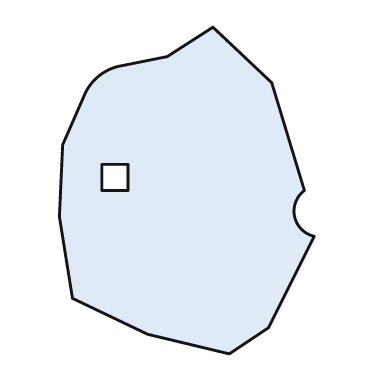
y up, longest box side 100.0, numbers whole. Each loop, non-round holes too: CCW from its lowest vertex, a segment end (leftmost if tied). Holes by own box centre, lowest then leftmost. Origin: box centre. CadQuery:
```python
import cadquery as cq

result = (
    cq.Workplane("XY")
    .moveTo(13.0, -50.0)
    .lineTo(25.0, -42.0)
    .lineTo(39.0, -14.0)
    .threePointArc((33.0, -8.0), (36.0, 0.0))
    .lineTo(26.0, 33.0)
    .lineTo(8.0, 50.0)
    .lineTo(-6.0, 41.0)
    .lineTo(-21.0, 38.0)
    .threePointArc((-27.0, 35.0), (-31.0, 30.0))
    .lineTo(-38.0, 14.0)
    .lineTo(-39.0, -8.0)
    .lineTo(-35.0, -33.0)
    .lineTo(-12.0, -44.0)
    .close()
    .moveTo(-26.0, 0.0)
    .lineTo(-18.0, 0.0)
    .lineTo(-18.0, 8.0)
    .lineTo(-26.0, 8.0)
    .close()
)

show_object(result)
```